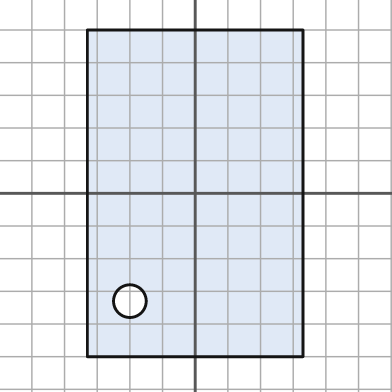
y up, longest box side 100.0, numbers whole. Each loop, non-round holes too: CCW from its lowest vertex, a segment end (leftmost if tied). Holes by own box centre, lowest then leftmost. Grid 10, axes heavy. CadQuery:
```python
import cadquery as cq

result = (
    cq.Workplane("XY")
    .moveTo(-33.0, -50.0)
    .lineTo(33.0, -50.0)
    .lineTo(33.0, 50.0)
    .lineTo(-33.0, 50.0)
    .close()
    .moveTo(-20.0, -33.0)
    .circle(5.0)
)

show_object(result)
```